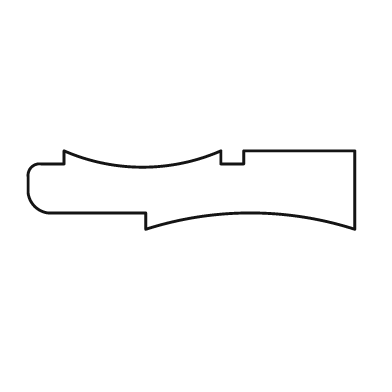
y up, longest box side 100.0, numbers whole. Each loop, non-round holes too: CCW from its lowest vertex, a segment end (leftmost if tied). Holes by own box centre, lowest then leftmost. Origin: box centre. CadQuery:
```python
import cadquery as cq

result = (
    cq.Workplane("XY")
    .moveTo(-14.0, -12.0)
    .threePointArc((18.0, -7.0), (50.0, -12.0))
    .lineTo(50.0, 12.0)
    .lineTo(16.0, 12.0)
    .lineTo(16.0, 8.0)
    .lineTo(9.0, 8.0)
    .lineTo(9.0, 12.0)
    .threePointArc((-15.0, 7.0), (-39.0, 12.0))
    .lineTo(-39.0, 8.0)
    .lineTo(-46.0, 8.0)
    .threePointArc((-49.0, 7.0), (-50.0, 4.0))
    .lineTo(-50.0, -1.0)
    .threePointArc((-48.0, -5.0), (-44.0, -7.0))
    .lineTo(-14.0, -7.0)
    .close()
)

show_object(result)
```